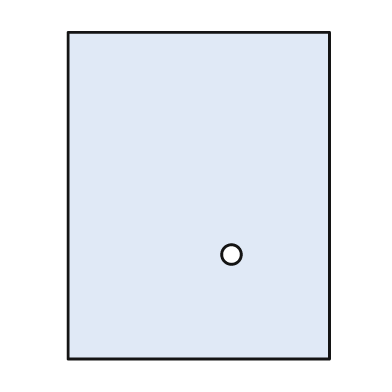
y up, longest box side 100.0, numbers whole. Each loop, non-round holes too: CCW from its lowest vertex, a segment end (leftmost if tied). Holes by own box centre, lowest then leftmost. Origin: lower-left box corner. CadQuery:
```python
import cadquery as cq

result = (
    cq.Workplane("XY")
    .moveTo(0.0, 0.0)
    .lineTo(80.0, 0.0)
    .lineTo(80.0, 100.0)
    .lineTo(0.0, 100.0)
    .close()
    .moveTo(50.0, 32.0)
    .circle(3.0)
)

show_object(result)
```